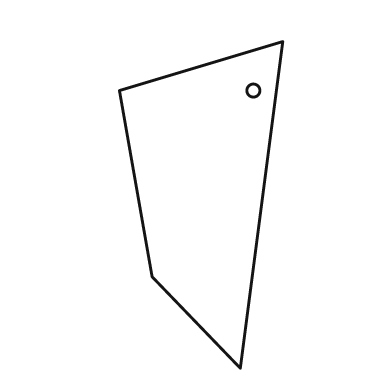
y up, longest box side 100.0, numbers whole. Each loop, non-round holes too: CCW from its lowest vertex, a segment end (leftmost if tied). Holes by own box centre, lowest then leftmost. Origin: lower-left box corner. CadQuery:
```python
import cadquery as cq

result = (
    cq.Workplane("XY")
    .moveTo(37.0, 0.0)
    .lineTo(50.0, 100.0)
    .lineTo(0.0, 85.0)
    .lineTo(10.0, 28.0)
    .close()
    .moveTo(41.0, 85.0)
    .circle(2.0)
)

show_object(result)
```